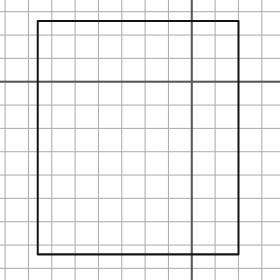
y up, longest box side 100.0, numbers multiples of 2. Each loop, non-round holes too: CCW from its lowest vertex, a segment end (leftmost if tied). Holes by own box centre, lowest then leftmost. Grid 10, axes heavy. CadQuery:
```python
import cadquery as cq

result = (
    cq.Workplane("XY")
    .moveTo(-66.0, -74.0)
    .lineTo(20.0, -74.0)
    .lineTo(20.0, 26.0)
    .lineTo(-66.0, 26.0)
    .close()
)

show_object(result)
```